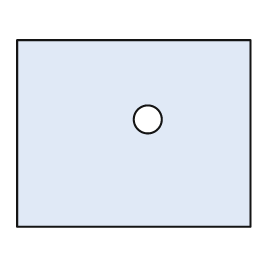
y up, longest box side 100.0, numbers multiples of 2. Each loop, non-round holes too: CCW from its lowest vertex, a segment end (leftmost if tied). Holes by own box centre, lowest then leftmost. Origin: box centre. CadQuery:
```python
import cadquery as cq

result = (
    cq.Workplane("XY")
    .moveTo(-50.0, -40.0)
    .lineTo(50.0, -40.0)
    .lineTo(50.0, 40.0)
    .lineTo(-50.0, 40.0)
    .close()
    .moveTo(6.0, 6.0)
    .circle(6.0)
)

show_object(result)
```